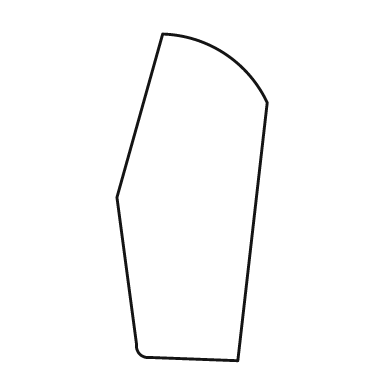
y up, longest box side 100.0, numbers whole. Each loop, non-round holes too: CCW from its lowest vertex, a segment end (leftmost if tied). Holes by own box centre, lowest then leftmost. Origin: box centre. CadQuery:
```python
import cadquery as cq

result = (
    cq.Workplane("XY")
    .moveTo(14.0, -50.0)
    .lineTo(23.0, 29.0)
    .threePointArc((10.0, 44.0), (-9.0, 50.0))
    .lineTo(-23.0, 0.0)
    .lineTo(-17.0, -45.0)
    .threePointArc((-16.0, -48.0), (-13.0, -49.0))
    .close()
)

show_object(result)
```